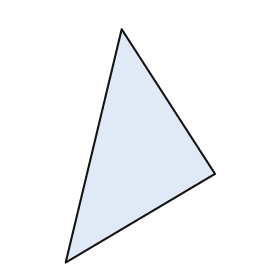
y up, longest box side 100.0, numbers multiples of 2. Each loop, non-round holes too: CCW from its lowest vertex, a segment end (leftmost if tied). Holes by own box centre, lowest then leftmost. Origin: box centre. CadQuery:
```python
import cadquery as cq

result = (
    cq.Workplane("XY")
    .moveTo(-32.0, -50.0)
    .lineTo(32.0, -12.0)
    .lineTo(-8.0, 50.0)
    .close()
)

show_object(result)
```